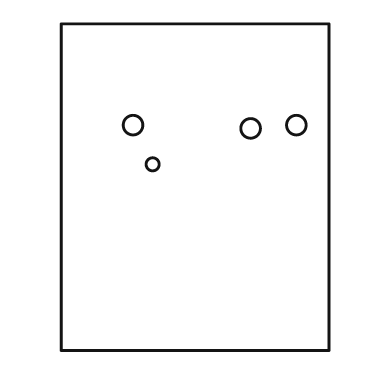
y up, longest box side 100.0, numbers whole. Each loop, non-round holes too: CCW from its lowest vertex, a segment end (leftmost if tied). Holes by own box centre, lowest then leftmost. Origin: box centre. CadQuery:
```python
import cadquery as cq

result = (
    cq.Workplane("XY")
    .moveTo(-41.0, -50.0)
    .lineTo(41.0, -50.0)
    .lineTo(41.0, 50.0)
    .lineTo(-41.0, 50.0)
    .close()
    .moveTo(-13.0, 7.0)
    .circle(2.0)
    .moveTo(17.0, 18.0)
    .circle(3.0)
    .moveTo(-19.0, 19.0)
    .circle(3.0)
    .moveTo(31.0, 19.0)
    .circle(3.0)
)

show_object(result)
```